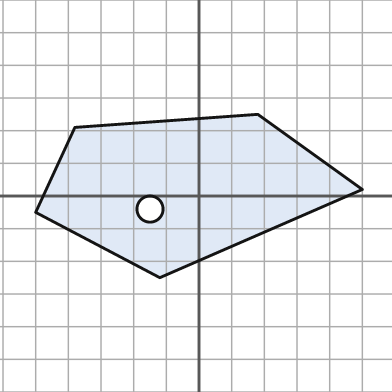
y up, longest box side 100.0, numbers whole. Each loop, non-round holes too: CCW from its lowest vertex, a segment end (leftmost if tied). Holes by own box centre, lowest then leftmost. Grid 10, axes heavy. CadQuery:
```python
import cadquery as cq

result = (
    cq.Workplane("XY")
    .moveTo(-12.0, -25.0)
    .lineTo(50.0, 2.0)
    .lineTo(18.0, 25.0)
    .lineTo(-38.0, 21.0)
    .lineTo(-50.0, -5.0)
    .close()
    .moveTo(-15.0, -4.0)
    .circle(4.0)
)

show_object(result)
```